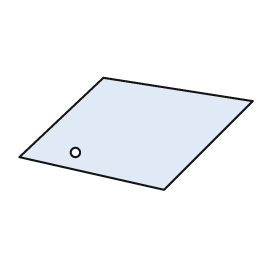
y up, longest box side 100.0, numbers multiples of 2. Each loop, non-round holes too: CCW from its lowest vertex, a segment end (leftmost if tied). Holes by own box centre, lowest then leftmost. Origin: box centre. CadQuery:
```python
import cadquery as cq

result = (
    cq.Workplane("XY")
    .moveTo(12.0, -24.0)
    .lineTo(50.0, 14.0)
    .lineTo(-14.0, 24.0)
    .lineTo(-50.0, -10.0)
    .close()
    .moveTo(-26.0, -8.0)
    .circle(2.0)
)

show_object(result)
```